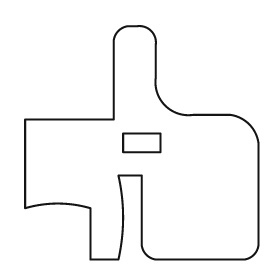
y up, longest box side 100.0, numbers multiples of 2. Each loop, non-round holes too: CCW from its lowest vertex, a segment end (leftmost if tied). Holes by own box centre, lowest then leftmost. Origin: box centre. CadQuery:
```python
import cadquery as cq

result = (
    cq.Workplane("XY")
    .moveTo(-22.0, -50.0)
    .lineTo(-10.0, -50.0)
    .threePointArc((-8.0, -32.0), (-10.0, -14.0))
    .lineTo(0.0, -14.0)
    .lineTo(0.0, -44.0)
    .threePointArc((2.0, -48.0), (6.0, -50.0))
    .lineTo(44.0, -50.0)
    .threePointArc((48.0, -48.0), (50.0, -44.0))
    .lineTo(50.0, 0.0)
    .threePointArc((46.0, 8.0), (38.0, 12.0))
    .lineTo(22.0, 12.0)
    .threePointArc((10.0, 16.0), (6.0, 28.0))
    .lineTo(6.0, 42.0)
    .threePointArc((4.0, 48.0), (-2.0, 50.0))
    .lineTo(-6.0, 50.0)
    .threePointArc((-10.0, 48.0), (-12.0, 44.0))
    .lineTo(-12.0, 10.0)
    .lineTo(-50.0, 10.0)
    .lineTo(-50.0, -28.0)
    .threePointArc((-36.0, -26.0), (-22.0, -28.0))
    .close()
    .moveTo(-8.0, -4.0)
    .lineTo(8.0, -4.0)
    .lineTo(8.0, 4.0)
    .lineTo(-8.0, 4.0)
    .close()
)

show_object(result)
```